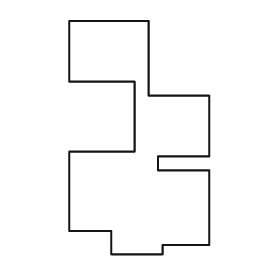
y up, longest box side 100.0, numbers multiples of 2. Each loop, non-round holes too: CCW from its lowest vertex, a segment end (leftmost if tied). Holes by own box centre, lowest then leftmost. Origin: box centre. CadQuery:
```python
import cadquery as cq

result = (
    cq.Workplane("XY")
    .moveTo(-12.0, -50.0)
    .lineTo(10.0, -50.0)
    .lineTo(10.0, -46.0)
    .lineTo(30.0, -46.0)
    .lineTo(30.0, -14.0)
    .lineTo(8.0, -14.0)
    .lineTo(8.0, -8.0)
    .lineTo(30.0, -8.0)
    .lineTo(30.0, 18.0)
    .lineTo(4.0, 18.0)
    .lineTo(4.0, 50.0)
    .lineTo(-30.0, 50.0)
    .lineTo(-30.0, 24.0)
    .lineTo(-2.0, 24.0)
    .lineTo(-2.0, -6.0)
    .lineTo(-30.0, -6.0)
    .lineTo(-30.0, -40.0)
    .lineTo(-12.0, -40.0)
    .close()
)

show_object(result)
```